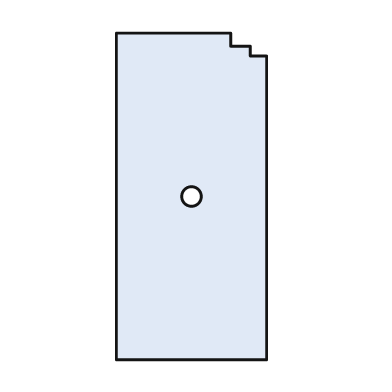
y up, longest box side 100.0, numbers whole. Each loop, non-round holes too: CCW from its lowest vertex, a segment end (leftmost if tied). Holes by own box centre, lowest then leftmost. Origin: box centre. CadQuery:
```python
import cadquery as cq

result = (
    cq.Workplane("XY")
    .moveTo(-23.0, -50.0)
    .lineTo(23.0, -50.0)
    .lineTo(23.0, 43.0)
    .lineTo(18.0, 43.0)
    .lineTo(18.0, 46.0)
    .lineTo(12.0, 46.0)
    .lineTo(12.0, 50.0)
    .lineTo(-23.0, 50.0)
    .close()
    .moveTo(0.0, 0.0)
    .circle(3.0)
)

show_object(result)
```